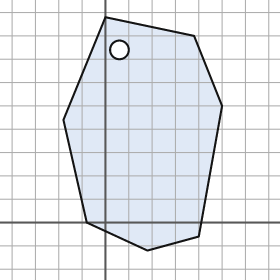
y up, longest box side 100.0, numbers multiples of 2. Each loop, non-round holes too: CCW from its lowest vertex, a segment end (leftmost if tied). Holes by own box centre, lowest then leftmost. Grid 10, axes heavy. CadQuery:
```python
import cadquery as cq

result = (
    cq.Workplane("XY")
    .moveTo(18.0, -12.0)
    .lineTo(40.0, -6.0)
    .lineTo(50.0, 50.0)
    .lineTo(38.0, 80.0)
    .lineTo(0.0, 88.0)
    .lineTo(-18.0, 44.0)
    .lineTo(-8.0, 0.0)
    .close()
    .moveTo(6.0, 74.0)
    .circle(4.0)
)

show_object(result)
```